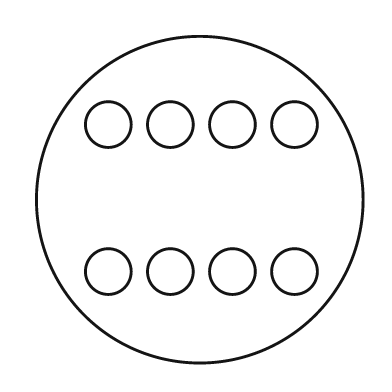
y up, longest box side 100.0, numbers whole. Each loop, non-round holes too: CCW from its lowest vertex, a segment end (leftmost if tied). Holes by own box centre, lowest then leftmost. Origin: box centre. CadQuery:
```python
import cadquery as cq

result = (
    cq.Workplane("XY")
    .moveTo(0.0, 0.0)
    .circle(50.0)
    .moveTo(-28.0, -22.0)
    .circle(7.0)
    .moveTo(-9.0, -22.0)
    .circle(7.0)
    .moveTo(10.0, -22.0)
    .circle(7.0)
    .moveTo(29.0, -22.0)
    .circle(7.0)
    .moveTo(-28.0, 23.0)
    .circle(7.0)
    .moveTo(-9.0, 23.0)
    .circle(7.0)
    .moveTo(10.0, 23.0)
    .circle(7.0)
    .moveTo(29.0, 23.0)
    .circle(7.0)
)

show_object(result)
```